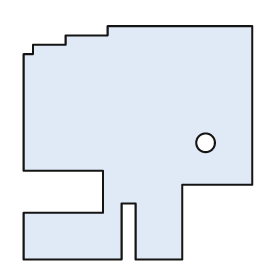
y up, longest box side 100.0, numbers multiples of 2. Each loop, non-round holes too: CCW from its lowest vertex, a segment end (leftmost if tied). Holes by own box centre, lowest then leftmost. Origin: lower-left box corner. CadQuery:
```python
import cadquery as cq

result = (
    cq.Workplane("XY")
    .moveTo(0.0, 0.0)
    .lineTo(42.0, 0.0)
    .lineTo(42.0, 24.0)
    .lineTo(48.0, 24.0)
    .lineTo(48.0, 0.0)
    .lineTo(68.0, 0.0)
    .lineTo(68.0, 32.0)
    .lineTo(98.0, 32.0)
    .lineTo(98.0, 100.0)
    .lineTo(36.0, 100.0)
    .lineTo(36.0, 96.0)
    .lineTo(18.0, 96.0)
    .lineTo(18.0, 92.0)
    .lineTo(4.0, 92.0)
    .lineTo(4.0, 88.0)
    .lineTo(0.0, 88.0)
    .lineTo(0.0, 38.0)
    .lineTo(34.0, 38.0)
    .lineTo(34.0, 20.0)
    .lineTo(0.0, 20.0)
    .close()
    .moveTo(78.0, 50.0)
    .circle(4.0)
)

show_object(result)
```